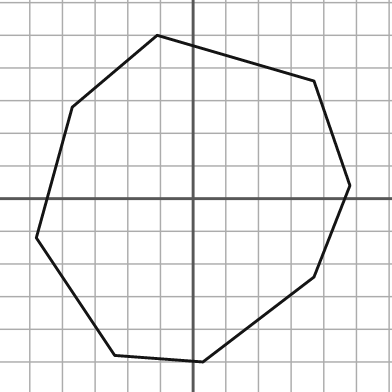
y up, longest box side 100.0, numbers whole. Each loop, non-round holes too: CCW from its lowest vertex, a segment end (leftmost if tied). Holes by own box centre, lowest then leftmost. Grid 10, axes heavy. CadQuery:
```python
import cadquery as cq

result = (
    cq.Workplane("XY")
    .moveTo(3.0, -50.0)
    .lineTo(37.0, -24.0)
    .lineTo(48.0, 4.0)
    .lineTo(37.0, 36.0)
    .lineTo(-11.0, 50.0)
    .lineTo(-37.0, 28.0)
    .lineTo(-48.0, -12.0)
    .lineTo(-24.0, -48.0)
    .close()
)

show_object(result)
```